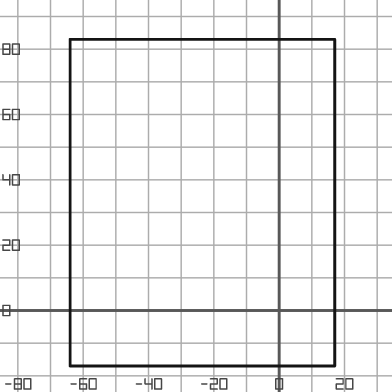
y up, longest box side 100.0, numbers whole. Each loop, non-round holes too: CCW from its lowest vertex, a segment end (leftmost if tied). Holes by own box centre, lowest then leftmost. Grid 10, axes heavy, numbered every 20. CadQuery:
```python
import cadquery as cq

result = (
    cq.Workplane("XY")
    .moveTo(-64.0, -17.0)
    .lineTo(17.0, -17.0)
    .lineTo(17.0, 83.0)
    .lineTo(-64.0, 83.0)
    .close()
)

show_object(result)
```